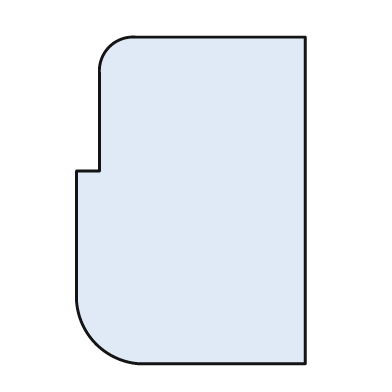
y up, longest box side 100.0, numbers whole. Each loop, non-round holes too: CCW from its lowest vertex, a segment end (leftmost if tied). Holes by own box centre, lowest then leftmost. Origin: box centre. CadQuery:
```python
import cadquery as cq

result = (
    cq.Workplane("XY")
    .moveTo(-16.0, -50.0)
    .lineTo(35.0, -50.0)
    .lineTo(35.0, 50.0)
    .lineTo(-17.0, 50.0)
    .threePointArc((-25.0, 47.0), (-28.0, 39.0))
    .lineTo(-28.0, 9.0)
    .lineTo(-35.0, 9.0)
    .lineTo(-35.0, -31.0)
    .threePointArc((-29.0, -44.0), (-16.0, -50.0))
    .close()
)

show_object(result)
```